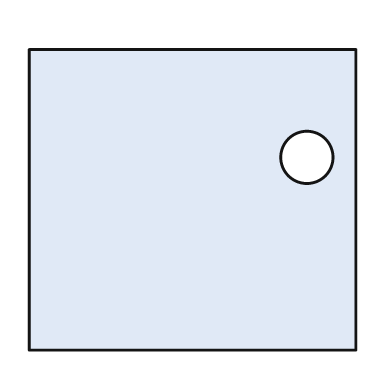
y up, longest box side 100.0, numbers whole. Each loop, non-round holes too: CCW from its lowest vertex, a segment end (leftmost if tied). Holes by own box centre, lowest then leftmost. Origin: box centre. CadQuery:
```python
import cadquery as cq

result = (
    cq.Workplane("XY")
    .moveTo(-50.0, -46.0)
    .lineTo(50.0, -46.0)
    .lineTo(50.0, 46.0)
    .lineTo(-50.0, 46.0)
    .close()
    .moveTo(35.0, 13.0)
    .circle(8.0)
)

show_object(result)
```